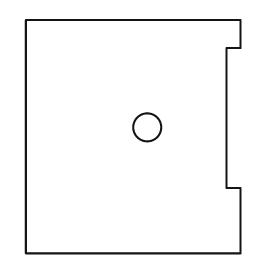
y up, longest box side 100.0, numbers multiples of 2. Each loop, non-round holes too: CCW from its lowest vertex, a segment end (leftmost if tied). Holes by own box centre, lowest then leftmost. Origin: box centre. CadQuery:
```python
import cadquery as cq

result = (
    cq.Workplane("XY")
    .moveTo(-46.0, -50.0)
    .lineTo(46.0, -50.0)
    .lineTo(46.0, -22.0)
    .lineTo(40.0, -22.0)
    .lineTo(40.0, 38.0)
    .lineTo(46.0, 38.0)
    .lineTo(46.0, 50.0)
    .lineTo(-46.0, 50.0)
    .close()
    .moveTo(6.0, 4.0)
    .circle(6.0)
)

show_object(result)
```